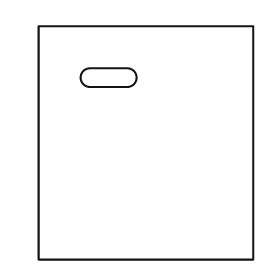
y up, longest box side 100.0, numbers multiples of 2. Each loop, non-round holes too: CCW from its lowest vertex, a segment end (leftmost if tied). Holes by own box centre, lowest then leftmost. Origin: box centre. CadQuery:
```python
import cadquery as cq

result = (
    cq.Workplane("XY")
    .moveTo(-46.0, -50.0)
    .lineTo(46.0, -50.0)
    .lineTo(46.0, 50.0)
    .lineTo(-46.0, 50.0)
    .close()
    .moveTo(-24.0, 24.0)
    .lineTo(-8.0, 24.0)
    .threePointArc((-4.0, 28.0), (-8.0, 32.0))
    .lineTo(-24.0, 32.0)
    .threePointArc((-28.0, 28.0), (-24.0, 24.0))
    .close()
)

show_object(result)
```